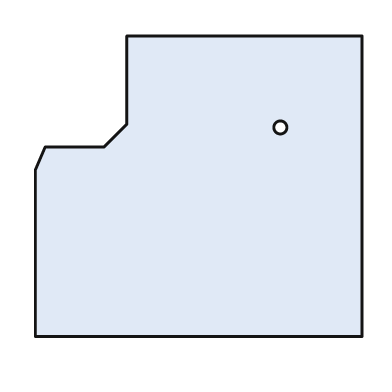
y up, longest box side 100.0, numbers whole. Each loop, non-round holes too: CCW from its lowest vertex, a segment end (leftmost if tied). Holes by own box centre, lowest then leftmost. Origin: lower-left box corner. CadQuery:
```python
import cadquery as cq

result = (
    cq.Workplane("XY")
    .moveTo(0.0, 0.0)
    .lineTo(100.0, 0.0)
    .lineTo(100.0, 92.0)
    .lineTo(28.0, 92.0)
    .lineTo(28.0, 65.0)
    .lineTo(21.0, 58.0)
    .lineTo(3.0, 58.0)
    .lineTo(0.0, 51.0)
    .close()
    .moveTo(75.0, 64.0)
    .circle(2.0)
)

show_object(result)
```